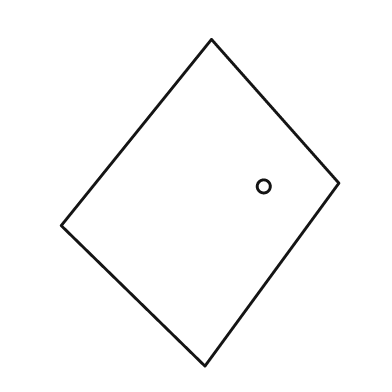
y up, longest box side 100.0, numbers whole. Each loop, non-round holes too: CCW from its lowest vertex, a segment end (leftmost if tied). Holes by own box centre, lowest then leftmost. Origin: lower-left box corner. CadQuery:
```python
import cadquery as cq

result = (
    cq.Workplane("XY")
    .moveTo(44.0, 0.0)
    .lineTo(85.0, 56.0)
    .lineTo(46.0, 100.0)
    .lineTo(0.0, 43.0)
    .close()
    .moveTo(62.0, 55.0)
    .circle(2.0)
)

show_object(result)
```